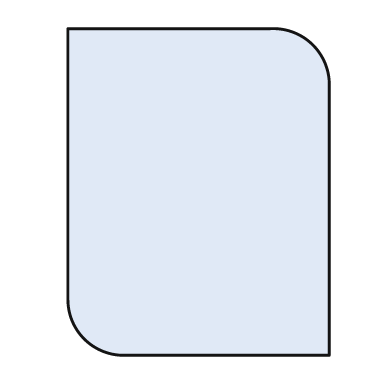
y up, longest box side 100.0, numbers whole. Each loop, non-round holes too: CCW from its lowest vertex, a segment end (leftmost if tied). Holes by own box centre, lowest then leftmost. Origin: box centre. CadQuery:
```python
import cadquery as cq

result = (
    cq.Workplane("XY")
    .moveTo(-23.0, -50.0)
    .lineTo(40.0, -50.0)
    .lineTo(40.0, 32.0)
    .threePointArc((35.0, 45.0), (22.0, 50.0))
    .lineTo(-40.0, 50.0)
    .lineTo(-40.0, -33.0)
    .threePointArc((-35.0, -45.0), (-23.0, -50.0))
    .close()
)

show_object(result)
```